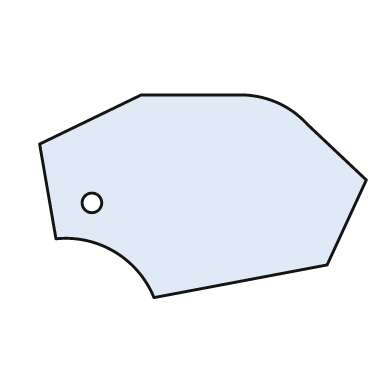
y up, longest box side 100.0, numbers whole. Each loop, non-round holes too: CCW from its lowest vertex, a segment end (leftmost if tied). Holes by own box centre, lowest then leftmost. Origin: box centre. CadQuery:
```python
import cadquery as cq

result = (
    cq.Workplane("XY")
    .moveTo(-15.0, -31.0)
    .lineTo(38.0, -21.0)
    .lineTo(50.0, 5.0)
    .lineTo(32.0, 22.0)
    .threePointArc((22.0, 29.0), (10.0, 31.0))
    .lineTo(-19.0, 31.0)
    .lineTo(-50.0, 16.0)
    .lineTo(-45.0, -13.0)
    .threePointArc((-27.0, -17.0), (-15.0, -31.0))
    .close()
    .moveTo(-34.0, -2.0)
    .circle(3.0)
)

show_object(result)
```